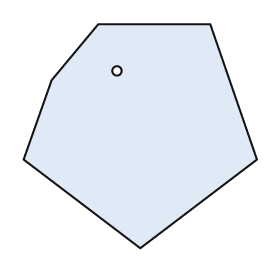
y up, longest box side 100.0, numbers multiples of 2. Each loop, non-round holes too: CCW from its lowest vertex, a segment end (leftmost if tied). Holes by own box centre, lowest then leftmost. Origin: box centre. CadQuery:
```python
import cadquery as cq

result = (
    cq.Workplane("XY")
    .moveTo(0.0, -48.0)
    .lineTo(50.0, -10.0)
    .lineTo(30.0, 48.0)
    .lineTo(-18.0, 48.0)
    .lineTo(-38.0, 24.0)
    .lineTo(-50.0, -10.0)
    .close()
    .moveTo(-10.0, 28.0)
    .circle(2.0)
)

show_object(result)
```